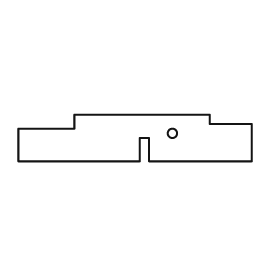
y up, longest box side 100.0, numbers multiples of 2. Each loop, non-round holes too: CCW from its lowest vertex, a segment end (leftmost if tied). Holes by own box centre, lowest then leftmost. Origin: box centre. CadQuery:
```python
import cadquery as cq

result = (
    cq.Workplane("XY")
    .moveTo(-50.0, -10.0)
    .lineTo(2.0, -10.0)
    .lineTo(2.0, 0.0)
    .lineTo(6.0, 0.0)
    .lineTo(6.0, -10.0)
    .lineTo(50.0, -10.0)
    .lineTo(50.0, 6.0)
    .lineTo(32.0, 6.0)
    .lineTo(32.0, 10.0)
    .lineTo(-26.0, 10.0)
    .lineTo(-26.0, 4.0)
    .lineTo(-50.0, 4.0)
    .close()
    .moveTo(16.0, 2.0)
    .circle(2.0)
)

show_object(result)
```